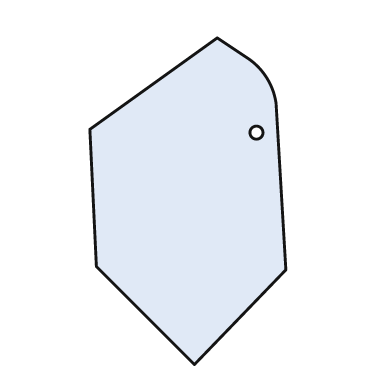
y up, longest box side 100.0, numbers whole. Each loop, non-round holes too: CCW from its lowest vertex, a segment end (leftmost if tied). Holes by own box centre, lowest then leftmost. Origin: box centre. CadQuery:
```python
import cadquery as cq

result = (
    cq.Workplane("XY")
    .moveTo(2.0, -50.0)
    .lineTo(30.0, -21.0)
    .lineTo(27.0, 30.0)
    .threePointArc((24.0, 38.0), (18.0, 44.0))
    .lineTo(9.0, 50.0)
    .lineTo(-30.0, 22.0)
    .lineTo(-28.0, -20.0)
    .close()
    .moveTo(21.0, 21.0)
    .circle(2.0)
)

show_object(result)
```